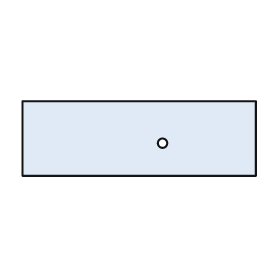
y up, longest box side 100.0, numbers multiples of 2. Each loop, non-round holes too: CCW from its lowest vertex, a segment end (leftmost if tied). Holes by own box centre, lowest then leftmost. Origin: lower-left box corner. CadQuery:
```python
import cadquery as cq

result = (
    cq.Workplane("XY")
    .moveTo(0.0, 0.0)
    .lineTo(100.0, 0.0)
    .lineTo(100.0, 32.0)
    .lineTo(0.0, 32.0)
    .close()
    .moveTo(60.0, 14.0)
    .circle(2.0)
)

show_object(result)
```